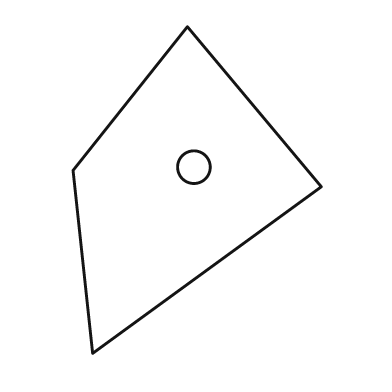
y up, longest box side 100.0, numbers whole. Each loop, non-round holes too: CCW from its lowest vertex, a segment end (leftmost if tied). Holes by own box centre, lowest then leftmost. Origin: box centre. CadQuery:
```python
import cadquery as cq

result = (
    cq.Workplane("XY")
    .moveTo(-32.0, -50.0)
    .lineTo(38.0, 1.0)
    .lineTo(-3.0, 50.0)
    .lineTo(-38.0, 6.0)
    .close()
    .moveTo(-1.0, 7.0)
    .circle(5.0)
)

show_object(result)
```